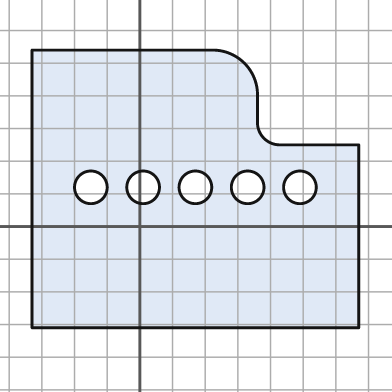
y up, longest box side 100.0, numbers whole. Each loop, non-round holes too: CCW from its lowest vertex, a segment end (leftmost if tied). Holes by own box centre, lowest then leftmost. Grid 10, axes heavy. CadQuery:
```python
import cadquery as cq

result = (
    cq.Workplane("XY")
    .moveTo(-33.0, -31.0)
    .lineTo(67.0, -31.0)
    .lineTo(67.0, 25.0)
    .lineTo(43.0, 25.0)
    .threePointArc((38.0, 27.0), (36.0, 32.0))
    .lineTo(36.0, 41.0)
    .threePointArc((32.0, 50.0), (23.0, 54.0))
    .lineTo(-33.0, 54.0)
    .close()
    .moveTo(-15.0, 12.0)
    .circle(5.0)
    .moveTo(1.0, 12.0)
    .circle(5.0)
    .moveTo(17.0, 12.0)
    .circle(5.0)
    .moveTo(33.0, 12.0)
    .circle(5.0)
    .moveTo(49.0, 12.0)
    .circle(5.0)
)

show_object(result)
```